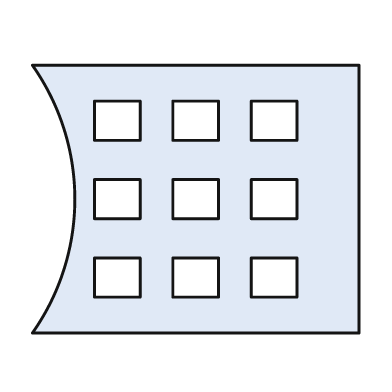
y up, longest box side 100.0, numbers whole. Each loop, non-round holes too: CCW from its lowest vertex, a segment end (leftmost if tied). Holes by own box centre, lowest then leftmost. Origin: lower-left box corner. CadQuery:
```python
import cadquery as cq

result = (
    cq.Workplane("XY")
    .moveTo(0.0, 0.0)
    .lineTo(100.0, 0.0)
    .lineTo(100.0, 82.0)
    .lineTo(0.0, 82.0)
    .threePointArc((13.0, 41.0), (0.0, 0.0))
    .close()
    .moveTo(19.0, 11.0)
    .lineTo(33.0, 11.0)
    .lineTo(33.0, 23.0)
    .lineTo(19.0, 23.0)
    .close()
    .moveTo(43.0, 11.0)
    .lineTo(57.0, 11.0)
    .lineTo(57.0, 23.0)
    .lineTo(43.0, 23.0)
    .close()
    .moveTo(67.0, 11.0)
    .lineTo(81.0, 11.0)
    .lineTo(81.0, 23.0)
    .lineTo(67.0, 23.0)
    .close()
    .moveTo(19.0, 35.0)
    .lineTo(33.0, 35.0)
    .lineTo(33.0, 47.0)
    .lineTo(19.0, 47.0)
    .close()
    .moveTo(43.0, 35.0)
    .lineTo(57.0, 35.0)
    .lineTo(57.0, 47.0)
    .lineTo(43.0, 47.0)
    .close()
    .moveTo(67.0, 35.0)
    .lineTo(81.0, 35.0)
    .lineTo(81.0, 47.0)
    .lineTo(67.0, 47.0)
    .close()
    .moveTo(19.0, 59.0)
    .lineTo(33.0, 59.0)
    .lineTo(33.0, 71.0)
    .lineTo(19.0, 71.0)
    .close()
    .moveTo(43.0, 59.0)
    .lineTo(57.0, 59.0)
    .lineTo(57.0, 71.0)
    .lineTo(43.0, 71.0)
    .close()
    .moveTo(67.0, 59.0)
    .lineTo(81.0, 59.0)
    .lineTo(81.0, 71.0)
    .lineTo(67.0, 71.0)
    .close()
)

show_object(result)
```